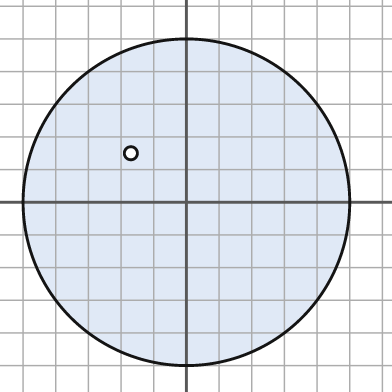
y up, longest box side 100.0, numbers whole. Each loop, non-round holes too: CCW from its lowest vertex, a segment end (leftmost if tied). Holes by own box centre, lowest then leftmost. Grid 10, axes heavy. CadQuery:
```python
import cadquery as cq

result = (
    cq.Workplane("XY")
    .moveTo(0.0, 0.0)
    .circle(50.0)
    .moveTo(-17.0, 15.0)
    .circle(2.0)
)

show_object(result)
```